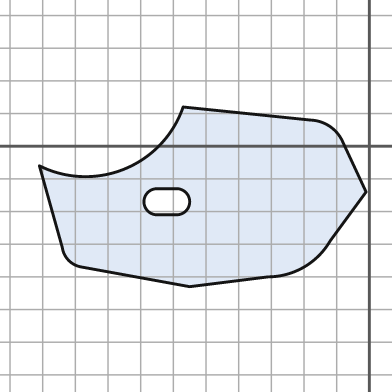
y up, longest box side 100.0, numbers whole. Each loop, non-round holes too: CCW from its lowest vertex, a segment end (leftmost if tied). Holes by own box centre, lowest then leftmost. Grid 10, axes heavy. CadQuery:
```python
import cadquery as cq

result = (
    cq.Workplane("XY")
    .moveTo(-55.0, -43.0)
    .lineTo(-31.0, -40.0)
    .threePointArc((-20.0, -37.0), (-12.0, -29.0))
    .lineTo(-1.0, -14.0)
    .lineTo(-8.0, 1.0)
    .threePointArc((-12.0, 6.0), (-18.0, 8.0))
    .lineTo(-57.0, 12.0)
    .threePointArc((-75.0, -7.0), (-101.0, -6.0))
    .lineTo(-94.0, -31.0)
    .threePointArc((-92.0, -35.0), (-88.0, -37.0))
    .close()
    .moveTo(-65.0, -21.0)
    .lineTo(-59.0, -21.0)
    .threePointArc((-55.0, -17.0), (-59.0, -13.0))
    .lineTo(-65.0, -13.0)
    .threePointArc((-69.0, -17.0), (-65.0, -21.0))
    .close()
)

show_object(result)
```